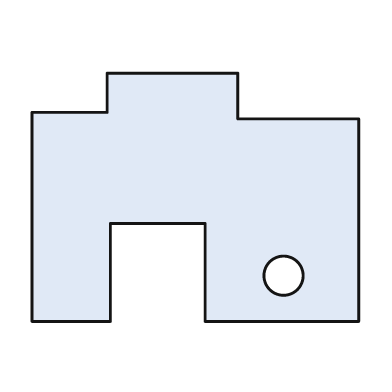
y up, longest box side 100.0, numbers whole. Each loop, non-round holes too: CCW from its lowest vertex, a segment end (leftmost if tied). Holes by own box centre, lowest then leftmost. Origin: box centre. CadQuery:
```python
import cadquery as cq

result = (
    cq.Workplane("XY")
    .moveTo(-50.0, -38.0)
    .lineTo(-26.0, -38.0)
    .lineTo(-26.0, -8.0)
    .lineTo(3.0, -8.0)
    .lineTo(3.0, -38.0)
    .lineTo(50.0, -38.0)
    .lineTo(50.0, 24.0)
    .lineTo(13.0, 24.0)
    .lineTo(13.0, 38.0)
    .lineTo(-27.0, 38.0)
    .lineTo(-27.0, 26.0)
    .lineTo(-50.0, 26.0)
    .close()
    .moveTo(27.0, -24.0)
    .circle(6.0)
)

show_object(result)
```